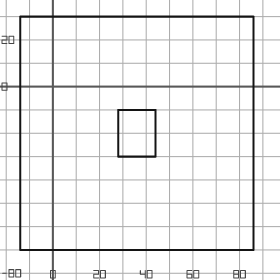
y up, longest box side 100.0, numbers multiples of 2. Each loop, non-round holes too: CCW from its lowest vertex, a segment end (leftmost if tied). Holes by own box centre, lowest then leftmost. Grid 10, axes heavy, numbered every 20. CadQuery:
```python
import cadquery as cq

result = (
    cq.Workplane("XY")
    .moveTo(-14.0, -70.0)
    .lineTo(86.0, -70.0)
    .lineTo(86.0, 30.0)
    .lineTo(-14.0, 30.0)
    .close()
    .moveTo(28.0, -30.0)
    .lineTo(44.0, -30.0)
    .lineTo(44.0, -10.0)
    .lineTo(28.0, -10.0)
    .close()
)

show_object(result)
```